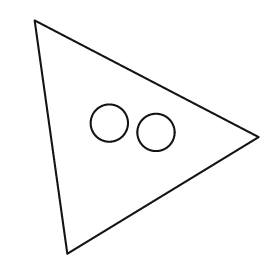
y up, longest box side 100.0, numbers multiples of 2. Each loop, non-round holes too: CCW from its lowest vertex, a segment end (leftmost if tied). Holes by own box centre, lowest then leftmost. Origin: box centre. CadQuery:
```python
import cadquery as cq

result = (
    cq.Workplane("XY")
    .moveTo(-34.0, -50.0)
    .lineTo(48.0, 0.0)
    .lineTo(-48.0, 50.0)
    .close()
    .moveTo(4.0, 2.0)
    .circle(8.0)
    .moveTo(-16.0, 6.0)
    .circle(8.0)
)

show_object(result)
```